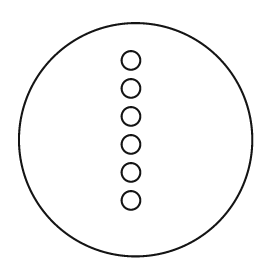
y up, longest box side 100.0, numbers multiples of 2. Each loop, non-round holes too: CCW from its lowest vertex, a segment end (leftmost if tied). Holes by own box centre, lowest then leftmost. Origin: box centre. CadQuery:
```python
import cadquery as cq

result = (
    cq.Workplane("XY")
    .moveTo(0.0, 0.0)
    .circle(50.0)
    .moveTo(-2.0, -26.0)
    .circle(4.0)
    .moveTo(-2.0, -14.0)
    .circle(4.0)
    .moveTo(-2.0, -2.0)
    .circle(4.0)
    .moveTo(-2.0, 10.0)
    .circle(4.0)
    .moveTo(-2.0, 22.0)
    .circle(4.0)
    .moveTo(-2.0, 34.0)
    .circle(4.0)
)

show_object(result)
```